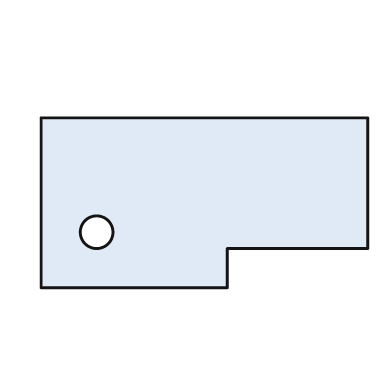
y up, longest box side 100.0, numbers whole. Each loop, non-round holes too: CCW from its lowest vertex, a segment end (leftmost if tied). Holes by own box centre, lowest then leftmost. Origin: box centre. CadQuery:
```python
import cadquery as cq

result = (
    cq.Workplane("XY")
    .moveTo(-50.0, -26.0)
    .lineTo(7.0, -26.0)
    .lineTo(7.0, -14.0)
    .lineTo(50.0, -14.0)
    .lineTo(50.0, 26.0)
    .lineTo(-50.0, 26.0)
    .close()
    .moveTo(-33.0, -9.0)
    .circle(5.0)
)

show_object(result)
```